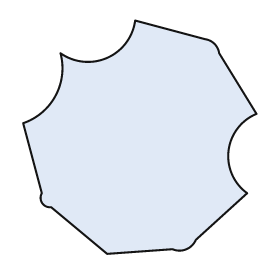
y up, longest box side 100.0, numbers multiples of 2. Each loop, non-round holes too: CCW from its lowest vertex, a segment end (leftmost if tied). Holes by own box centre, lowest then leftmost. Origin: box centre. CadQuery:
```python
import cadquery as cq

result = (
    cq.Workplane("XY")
    .moveTo(-14.0, -50.0)
    .lineTo(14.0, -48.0)
    .threePointArc((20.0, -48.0), (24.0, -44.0))
    .lineTo(46.0, -24.0)
    .threePointArc((38.0, -6.0), (50.0, 10.0))
    .lineTo(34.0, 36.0)
    .threePointArc((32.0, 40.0), (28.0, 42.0))
    .lineTo(-2.0, 50.0)
    .threePointArc((-14.0, 34.0), (-34.0, 36.0))
    .threePointArc((-36.0, 18.0), (-50.0, 6.0))
    .lineTo(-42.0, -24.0)
    .threePointArc((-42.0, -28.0), (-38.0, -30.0))
    .close()
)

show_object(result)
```